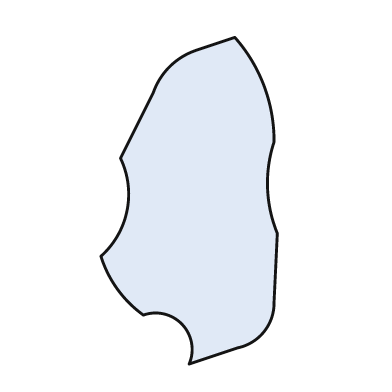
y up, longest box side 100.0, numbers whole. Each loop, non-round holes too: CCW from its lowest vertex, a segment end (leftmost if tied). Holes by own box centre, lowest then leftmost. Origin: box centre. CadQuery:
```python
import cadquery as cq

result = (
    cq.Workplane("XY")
    .moveTo(0.0, -50.0)
    .lineTo(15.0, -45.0)
    .threePointArc((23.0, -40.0), (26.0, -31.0))
    .lineTo(27.0, -10.0)
    .threePointArc((24.0, 4.0), (26.0, 18.0))
    .threePointArc((23.0, 35.0), (14.0, 50.0))
    .lineTo(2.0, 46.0)
    .threePointArc((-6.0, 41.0), (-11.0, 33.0))
    .lineTo(-21.0, 13.0)
    .threePointArc((-19.0, -3.0), (-27.0, -17.0))
    .threePointArc((-22.0, -27.0), (-14.0, -35.0))
    .threePointArc((-2.0, -38.0), (0.0, -50.0))
    .close()
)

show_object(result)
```